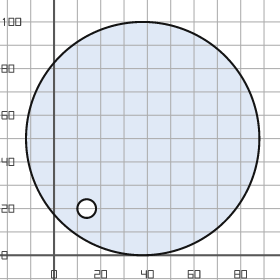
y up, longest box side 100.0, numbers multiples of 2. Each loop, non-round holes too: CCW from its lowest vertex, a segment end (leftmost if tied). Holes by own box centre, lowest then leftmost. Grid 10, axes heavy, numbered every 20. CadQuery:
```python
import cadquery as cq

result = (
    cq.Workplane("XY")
    .moveTo(38.0, 50.0)
    .circle(50.0)
    .moveTo(14.0, 20.0)
    .circle(4.0)
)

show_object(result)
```